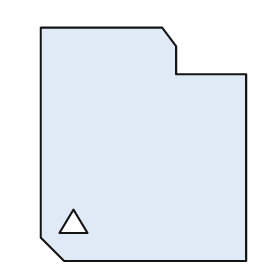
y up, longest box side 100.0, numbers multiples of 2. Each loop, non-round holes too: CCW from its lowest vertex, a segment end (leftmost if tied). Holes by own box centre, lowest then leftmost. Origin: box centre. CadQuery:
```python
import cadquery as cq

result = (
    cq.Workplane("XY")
    .moveTo(-34.0, -50.0)
    .lineTo(44.0, -50.0)
    .lineTo(44.0, 30.0)
    .lineTo(14.0, 30.0)
    .lineTo(14.0, 42.0)
    .lineTo(8.0, 50.0)
    .lineTo(-44.0, 50.0)
    .lineTo(-44.0, -40.0)
    .close()
    .moveTo(-36.0, -38.0)
    .lineTo(-24.0, -38.0)
    .lineTo(-30.0, -28.0)
    .close()
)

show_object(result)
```